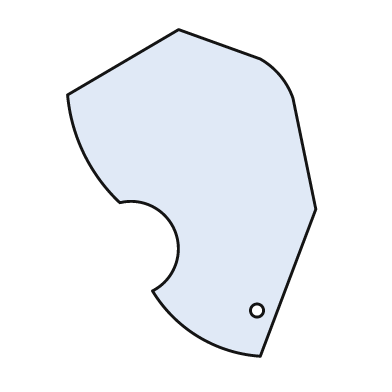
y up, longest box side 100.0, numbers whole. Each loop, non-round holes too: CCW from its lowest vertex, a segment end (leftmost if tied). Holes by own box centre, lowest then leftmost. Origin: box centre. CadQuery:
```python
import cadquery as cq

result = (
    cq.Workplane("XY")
    .moveTo(21.0, -50.0)
    .lineTo(38.0, -5.0)
    .lineTo(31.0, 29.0)
    .threePointArc((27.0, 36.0), (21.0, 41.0))
    .lineTo(-4.0, 50.0)
    .lineTo(-38.0, 30.0)
    .threePointArc((-33.0, 12.0), (-22.0, -3.0))
    .threePointArc((-5.0, -12.0), (-12.0, -30.0))
    .threePointArc((2.0, -44.0), (21.0, -50.0))
    .close()
    .moveTo(20.0, -36.0)
    .circle(2.0)
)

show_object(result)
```